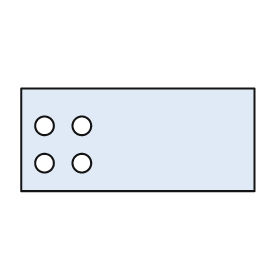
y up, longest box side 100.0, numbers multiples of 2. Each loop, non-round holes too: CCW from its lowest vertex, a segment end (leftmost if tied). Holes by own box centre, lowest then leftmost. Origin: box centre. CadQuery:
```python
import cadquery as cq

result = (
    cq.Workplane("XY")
    .moveTo(-50.0, -22.0)
    .lineTo(50.0, -22.0)
    .lineTo(50.0, 22.0)
    .lineTo(-50.0, 22.0)
    .close()
    .moveTo(-40.0, -10.0)
    .circle(4.0)
    .moveTo(-24.0, -10.0)
    .circle(4.0)
    .moveTo(-40.0, 6.0)
    .circle(4.0)
    .moveTo(-24.0, 6.0)
    .circle(4.0)
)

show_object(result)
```